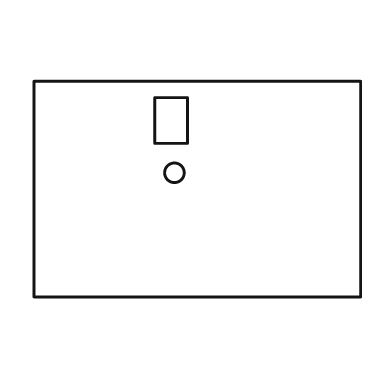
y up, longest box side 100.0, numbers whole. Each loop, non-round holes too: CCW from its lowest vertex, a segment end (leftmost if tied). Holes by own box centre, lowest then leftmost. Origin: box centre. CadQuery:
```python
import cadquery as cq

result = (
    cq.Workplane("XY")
    .moveTo(-50.0, -33.0)
    .lineTo(50.0, -33.0)
    .lineTo(50.0, 33.0)
    .lineTo(-50.0, 33.0)
    .close()
    .moveTo(-7.0, 5.0)
    .circle(3.0)
    .moveTo(-13.0, 14.0)
    .lineTo(-3.0, 14.0)
    .lineTo(-3.0, 28.0)
    .lineTo(-13.0, 28.0)
    .close()
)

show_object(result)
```